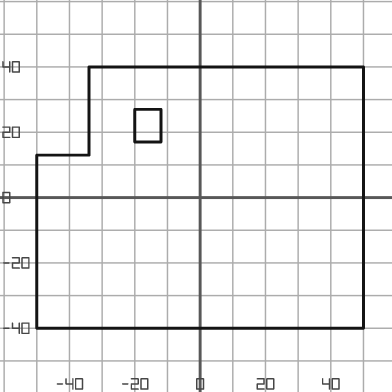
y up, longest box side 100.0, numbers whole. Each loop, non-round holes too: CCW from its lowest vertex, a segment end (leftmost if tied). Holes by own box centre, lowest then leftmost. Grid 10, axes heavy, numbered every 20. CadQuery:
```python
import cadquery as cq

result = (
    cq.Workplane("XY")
    .moveTo(-50.0, -40.0)
    .lineTo(50.0, -40.0)
    .lineTo(50.0, 40.0)
    .lineTo(-34.0, 40.0)
    .lineTo(-34.0, 13.0)
    .lineTo(-50.0, 13.0)
    .close()
    .moveTo(-20.0, 17.0)
    .lineTo(-12.0, 17.0)
    .lineTo(-12.0, 27.0)
    .lineTo(-20.0, 27.0)
    .close()
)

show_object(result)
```